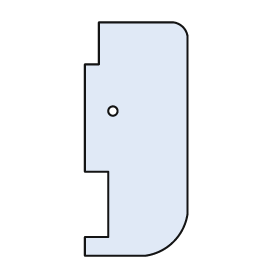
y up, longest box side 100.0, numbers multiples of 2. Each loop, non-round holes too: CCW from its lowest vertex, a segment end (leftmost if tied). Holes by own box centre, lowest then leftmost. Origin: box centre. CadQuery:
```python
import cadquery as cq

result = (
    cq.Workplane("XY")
    .moveTo(-22.0, -50.0)
    .lineTo(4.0, -50.0)
    .threePointArc((16.0, -44.0), (22.0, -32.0))
    .lineTo(22.0, 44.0)
    .threePointArc((20.0, 48.0), (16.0, 50.0))
    .lineTo(-16.0, 50.0)
    .lineTo(-16.0, 32.0)
    .lineTo(-22.0, 32.0)
    .lineTo(-22.0, -14.0)
    .lineTo(-12.0, -14.0)
    .lineTo(-12.0, -42.0)
    .lineTo(-22.0, -42.0)
    .close()
    .moveTo(-10.0, 12.0)
    .circle(2.0)
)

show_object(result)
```